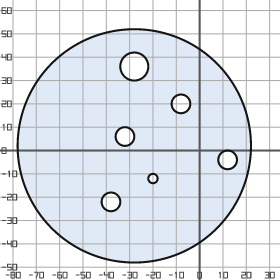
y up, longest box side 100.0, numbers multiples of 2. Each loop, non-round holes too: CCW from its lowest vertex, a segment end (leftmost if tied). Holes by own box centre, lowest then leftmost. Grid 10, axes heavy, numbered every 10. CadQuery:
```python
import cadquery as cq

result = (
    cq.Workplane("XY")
    .moveTo(-28.0, 2.0)
    .circle(50.0)
    .moveTo(-38.0, -22.0)
    .circle(4.0)
    .moveTo(-20.0, -12.0)
    .circle(2.0)
    .moveTo(12.0, -4.0)
    .circle(4.0)
    .moveTo(-32.0, 6.0)
    .circle(4.0)
    .moveTo(-8.0, 20.0)
    .circle(4.0)
    .moveTo(-28.0, 36.0)
    .circle(6.0)
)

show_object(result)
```